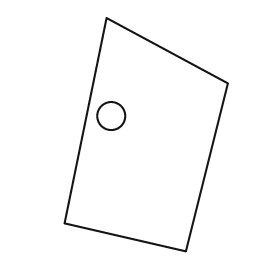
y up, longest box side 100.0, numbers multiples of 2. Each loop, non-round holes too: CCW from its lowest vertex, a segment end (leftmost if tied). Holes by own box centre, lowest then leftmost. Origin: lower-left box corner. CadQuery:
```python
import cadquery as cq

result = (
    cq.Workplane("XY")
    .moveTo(52.0, 0.0)
    .lineTo(70.0, 72.0)
    .lineTo(18.0, 100.0)
    .lineTo(0.0, 12.0)
    .close()
    .moveTo(20.0, 58.0)
    .circle(6.0)
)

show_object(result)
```